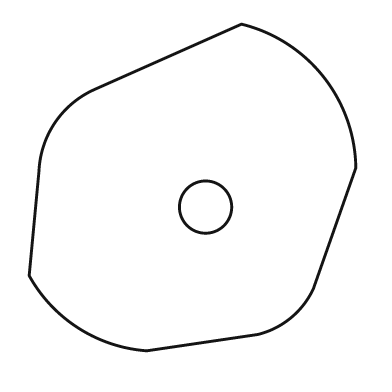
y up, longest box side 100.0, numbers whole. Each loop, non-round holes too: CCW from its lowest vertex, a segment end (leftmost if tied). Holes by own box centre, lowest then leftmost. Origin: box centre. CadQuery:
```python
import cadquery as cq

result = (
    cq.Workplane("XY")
    .moveTo(-14.0, -50.0)
    .lineTo(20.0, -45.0)
    .threePointArc((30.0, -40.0), (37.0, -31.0))
    .lineTo(50.0, 6.0)
    .threePointArc((40.0, 34.0), (15.0, 50.0))
    .lineTo(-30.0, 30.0)
    .threePointArc((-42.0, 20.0), (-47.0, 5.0))
    .lineTo(-50.0, -27.0)
    .threePointArc((-35.0, -43.0), (-14.0, -50.0))
    .close()
    .moveTo(4.0, -6.0)
    .circle(8.0)
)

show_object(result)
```